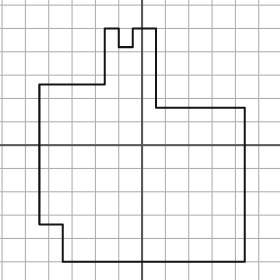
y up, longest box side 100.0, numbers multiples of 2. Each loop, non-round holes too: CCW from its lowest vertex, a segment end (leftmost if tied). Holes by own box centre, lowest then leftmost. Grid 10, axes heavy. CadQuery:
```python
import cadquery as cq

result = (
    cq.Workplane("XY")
    .moveTo(-34.0, -50.0)
    .lineTo(44.0, -50.0)
    .lineTo(44.0, 16.0)
    .lineTo(6.0, 16.0)
    .lineTo(6.0, 50.0)
    .lineTo(-4.0, 50.0)
    .lineTo(-4.0, 42.0)
    .lineTo(-10.0, 42.0)
    .lineTo(-10.0, 50.0)
    .lineTo(-16.0, 50.0)
    .lineTo(-16.0, 26.0)
    .lineTo(-44.0, 26.0)
    .lineTo(-44.0, -34.0)
    .lineTo(-34.0, -34.0)
    .close()
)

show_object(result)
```